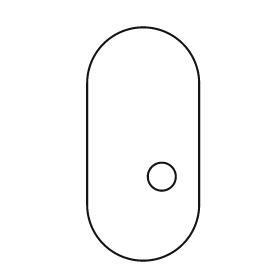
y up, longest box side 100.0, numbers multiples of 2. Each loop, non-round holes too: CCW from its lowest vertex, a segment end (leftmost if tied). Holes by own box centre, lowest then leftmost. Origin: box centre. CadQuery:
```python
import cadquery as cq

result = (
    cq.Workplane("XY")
    .moveTo(-24.0, -26.0)
    .threePointArc((0.0, -50.0), (24.0, -26.0))
    .lineTo(24.0, 26.0)
    .threePointArc((0.0, 50.0), (-24.0, 26.0))
    .close()
    .moveTo(8.0, -14.0)
    .circle(6.0)
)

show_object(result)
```